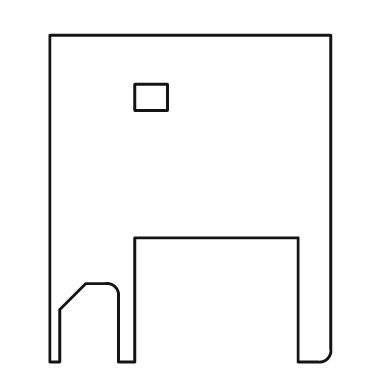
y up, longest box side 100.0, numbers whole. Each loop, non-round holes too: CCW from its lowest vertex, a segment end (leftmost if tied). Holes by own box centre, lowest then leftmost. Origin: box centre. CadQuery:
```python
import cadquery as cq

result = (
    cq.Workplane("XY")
    .moveTo(-43.0, -50.0)
    .lineTo(-40.0, -50.0)
    .lineTo(-40.0, -34.0)
    .lineTo(-32.0, -26.0)
    .lineTo(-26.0, -26.0)
    .threePointArc((-23.0, -27.0), (-22.0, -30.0))
    .lineTo(-22.0, -50.0)
    .lineTo(-17.0, -50.0)
    .lineTo(-17.0, -12.0)
    .lineTo(33.0, -12.0)
    .lineTo(33.0, -50.0)
    .lineTo(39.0, -50.0)
    .threePointArc((42.0, -49.0), (43.0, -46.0))
    .lineTo(43.0, 50.0)
    .lineTo(-43.0, 50.0)
    .close()
    .moveTo(-17.0, 27.0)
    .lineTo(-7.0, 27.0)
    .lineTo(-7.0, 35.0)
    .lineTo(-17.0, 35.0)
    .close()
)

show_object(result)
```